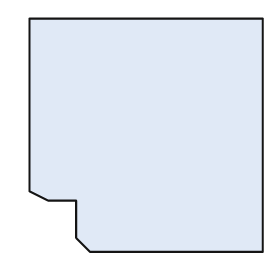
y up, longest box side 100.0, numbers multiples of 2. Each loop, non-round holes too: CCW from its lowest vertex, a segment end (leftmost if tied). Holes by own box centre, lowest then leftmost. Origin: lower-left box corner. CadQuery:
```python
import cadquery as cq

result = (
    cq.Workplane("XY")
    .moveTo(26.0, 0.0)
    .lineTo(100.0, 0.0)
    .lineTo(100.0, 100.0)
    .lineTo(0.0, 100.0)
    .lineTo(0.0, 26.0)
    .lineTo(8.0, 22.0)
    .lineTo(20.0, 22.0)
    .lineTo(20.0, 6.0)
    .close()
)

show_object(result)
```